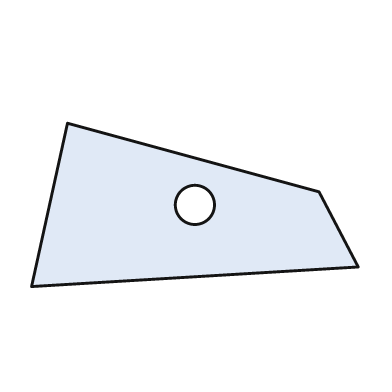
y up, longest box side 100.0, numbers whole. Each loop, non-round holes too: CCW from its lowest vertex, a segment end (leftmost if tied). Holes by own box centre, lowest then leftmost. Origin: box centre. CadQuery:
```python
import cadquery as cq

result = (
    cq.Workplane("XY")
    .moveTo(-50.0, -25.0)
    .lineTo(50.0, -19.0)
    .lineTo(38.0, 4.0)
    .lineTo(-39.0, 25.0)
    .close()
    .moveTo(0.0, 0.0)
    .circle(6.0)
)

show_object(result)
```